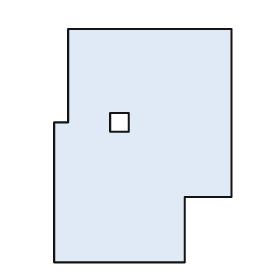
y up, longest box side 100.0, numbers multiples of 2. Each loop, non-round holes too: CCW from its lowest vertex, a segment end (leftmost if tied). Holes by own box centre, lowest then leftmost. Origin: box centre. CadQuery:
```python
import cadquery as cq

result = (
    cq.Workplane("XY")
    .moveTo(-38.0, -50.0)
    .lineTo(18.0, -50.0)
    .lineTo(18.0, -22.0)
    .lineTo(38.0, -22.0)
    .lineTo(38.0, 50.0)
    .lineTo(-32.0, 50.0)
    .lineTo(-32.0, 10.0)
    .lineTo(-38.0, 10.0)
    .close()
    .moveTo(-14.0, 6.0)
    .lineTo(-6.0, 6.0)
    .lineTo(-6.0, 14.0)
    .lineTo(-14.0, 14.0)
    .close()
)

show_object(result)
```